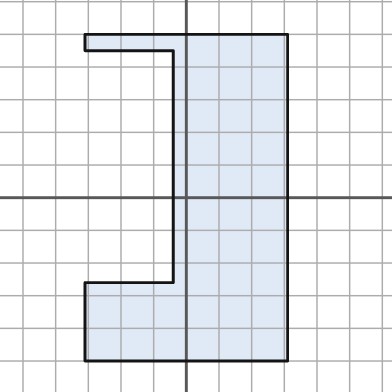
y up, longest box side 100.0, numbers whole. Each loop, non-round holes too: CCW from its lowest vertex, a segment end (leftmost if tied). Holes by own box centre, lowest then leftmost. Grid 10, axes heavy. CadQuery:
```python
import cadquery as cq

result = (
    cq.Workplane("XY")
    .moveTo(-31.0, -50.0)
    .lineTo(31.0, -50.0)
    .lineTo(31.0, 50.0)
    .lineTo(-31.0, 50.0)
    .lineTo(-31.0, 45.0)
    .lineTo(-4.0, 45.0)
    .lineTo(-4.0, -26.0)
    .lineTo(-31.0, -26.0)
    .close()
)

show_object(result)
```